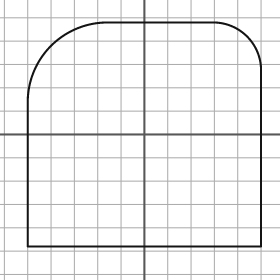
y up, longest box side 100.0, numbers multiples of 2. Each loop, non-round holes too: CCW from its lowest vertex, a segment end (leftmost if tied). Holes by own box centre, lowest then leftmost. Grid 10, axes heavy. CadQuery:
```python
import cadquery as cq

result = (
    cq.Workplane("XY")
    .moveTo(-50.0, -48.0)
    .lineTo(50.0, -48.0)
    .lineTo(50.0, 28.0)
    .threePointArc((44.0, 42.0), (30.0, 48.0))
    .lineTo(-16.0, 48.0)
    .threePointArc((-40.0, 38.0), (-50.0, 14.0))
    .close()
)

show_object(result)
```